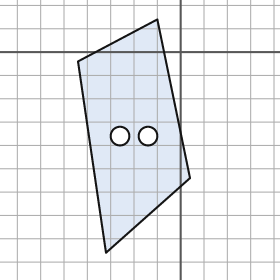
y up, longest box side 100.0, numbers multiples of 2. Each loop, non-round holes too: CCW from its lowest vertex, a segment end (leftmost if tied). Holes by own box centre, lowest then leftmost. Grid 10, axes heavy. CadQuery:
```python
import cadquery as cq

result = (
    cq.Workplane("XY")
    .moveTo(-32.0, -86.0)
    .lineTo(4.0, -54.0)
    .lineTo(-10.0, 14.0)
    .lineTo(-44.0, -4.0)
    .close()
    .moveTo(-26.0, -36.0)
    .circle(4.0)
    .moveTo(-14.0, -36.0)
    .circle(4.0)
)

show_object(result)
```